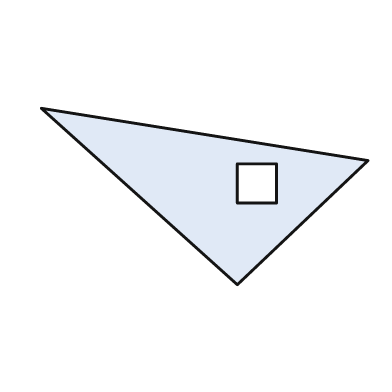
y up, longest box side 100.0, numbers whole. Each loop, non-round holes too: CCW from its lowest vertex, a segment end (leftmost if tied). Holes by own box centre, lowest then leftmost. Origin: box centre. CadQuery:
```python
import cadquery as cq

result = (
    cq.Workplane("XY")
    .moveTo(10.0, -27.0)
    .lineTo(50.0, 11.0)
    .lineTo(-50.0, 27.0)
    .close()
    .moveTo(10.0, -2.0)
    .lineTo(22.0, -2.0)
    .lineTo(22.0, 10.0)
    .lineTo(10.0, 10.0)
    .close()
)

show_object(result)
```